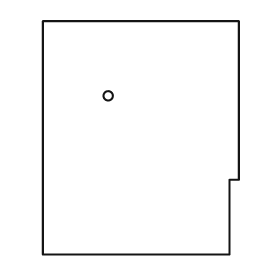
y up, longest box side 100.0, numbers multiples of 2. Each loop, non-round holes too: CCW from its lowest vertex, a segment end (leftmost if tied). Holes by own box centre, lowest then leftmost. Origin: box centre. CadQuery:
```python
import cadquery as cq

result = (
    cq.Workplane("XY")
    .moveTo(-42.0, -50.0)
    .lineTo(38.0, -50.0)
    .lineTo(38.0, -18.0)
    .lineTo(42.0, -18.0)
    .lineTo(42.0, 50.0)
    .lineTo(-42.0, 50.0)
    .close()
    .moveTo(-14.0, 18.0)
    .circle(2.0)
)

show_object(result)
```